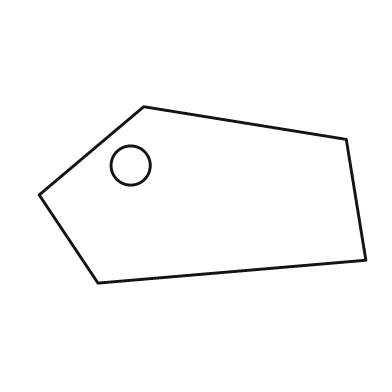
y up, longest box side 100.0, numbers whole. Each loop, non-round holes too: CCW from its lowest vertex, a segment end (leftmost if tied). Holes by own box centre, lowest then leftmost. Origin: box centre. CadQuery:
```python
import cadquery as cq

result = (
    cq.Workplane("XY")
    .moveTo(-32.0, -27.0)
    .lineTo(50.0, -20.0)
    .lineTo(44.0, 17.0)
    .lineTo(-18.0, 27.0)
    .lineTo(-50.0, 0.0)
    .close()
    .moveTo(-22.0, 9.0)
    .circle(6.0)
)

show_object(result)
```